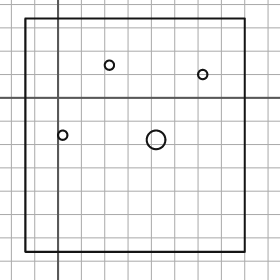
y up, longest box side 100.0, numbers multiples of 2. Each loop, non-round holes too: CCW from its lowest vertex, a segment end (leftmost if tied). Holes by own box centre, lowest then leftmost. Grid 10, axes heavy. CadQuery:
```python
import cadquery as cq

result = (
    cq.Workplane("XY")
    .moveTo(-14.0, -66.0)
    .lineTo(80.0, -66.0)
    .lineTo(80.0, 34.0)
    .lineTo(-14.0, 34.0)
    .close()
    .moveTo(42.0, -18.0)
    .circle(4.0)
    .moveTo(2.0, -16.0)
    .circle(2.0)
    .moveTo(62.0, 10.0)
    .circle(2.0)
    .moveTo(22.0, 14.0)
    .circle(2.0)
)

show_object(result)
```